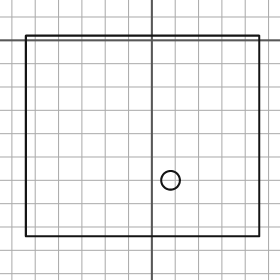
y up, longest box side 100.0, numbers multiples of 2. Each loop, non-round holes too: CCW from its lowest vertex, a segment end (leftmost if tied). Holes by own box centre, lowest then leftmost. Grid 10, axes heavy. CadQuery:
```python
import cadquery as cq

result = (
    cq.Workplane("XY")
    .moveTo(-54.0, -84.0)
    .lineTo(46.0, -84.0)
    .lineTo(46.0, 2.0)
    .lineTo(-54.0, 2.0)
    .close()
    .moveTo(8.0, -60.0)
    .circle(4.0)
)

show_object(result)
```